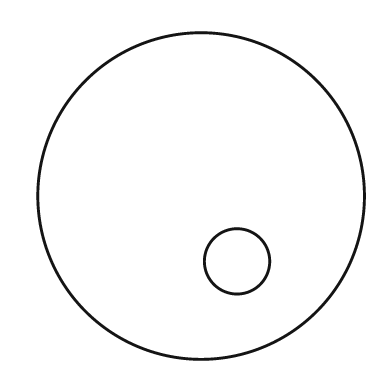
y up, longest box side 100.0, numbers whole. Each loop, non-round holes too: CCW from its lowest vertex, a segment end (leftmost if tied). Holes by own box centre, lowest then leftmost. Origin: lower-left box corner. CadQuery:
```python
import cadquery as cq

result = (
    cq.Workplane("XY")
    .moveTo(50.0, 50.0)
    .circle(50.0)
    .moveTo(61.0, 30.0)
    .circle(10.0)
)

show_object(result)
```